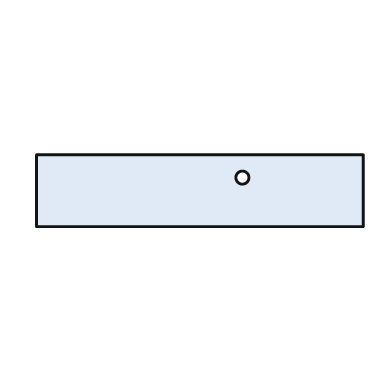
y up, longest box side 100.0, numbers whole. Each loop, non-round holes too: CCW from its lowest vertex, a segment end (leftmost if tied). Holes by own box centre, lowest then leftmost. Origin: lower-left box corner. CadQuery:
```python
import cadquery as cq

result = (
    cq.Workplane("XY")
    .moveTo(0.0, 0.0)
    .lineTo(100.0, 0.0)
    .lineTo(100.0, 22.0)
    .lineTo(0.0, 22.0)
    .close()
    .moveTo(63.0, 15.0)
    .circle(2.0)
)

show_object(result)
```